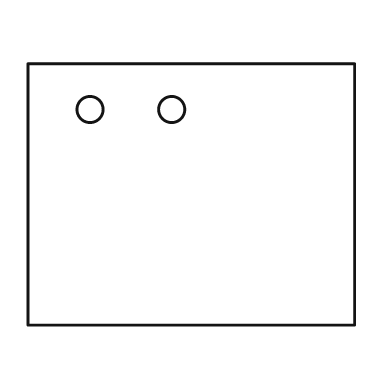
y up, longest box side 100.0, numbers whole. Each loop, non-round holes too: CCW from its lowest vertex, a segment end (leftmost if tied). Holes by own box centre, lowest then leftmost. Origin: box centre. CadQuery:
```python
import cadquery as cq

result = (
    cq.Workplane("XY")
    .moveTo(-50.0, -40.0)
    .lineTo(50.0, -40.0)
    .lineTo(50.0, 40.0)
    .lineTo(-50.0, 40.0)
    .close()
    .moveTo(-31.0, 26.0)
    .circle(4.0)
    .moveTo(-6.0, 26.0)
    .circle(4.0)
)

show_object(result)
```